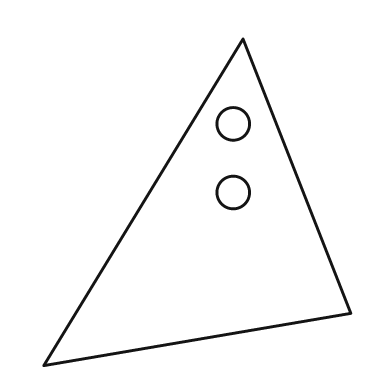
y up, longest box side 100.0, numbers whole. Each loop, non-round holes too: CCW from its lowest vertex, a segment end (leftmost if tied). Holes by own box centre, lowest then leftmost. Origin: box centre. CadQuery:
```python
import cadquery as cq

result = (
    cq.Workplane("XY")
    .moveTo(-47.0, -50.0)
    .lineTo(47.0, -34.0)
    .lineTo(14.0, 50.0)
    .close()
    .moveTo(11.0, 3.0)
    .circle(5.0)
    .moveTo(11.0, 24.0)
    .circle(5.0)
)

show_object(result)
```